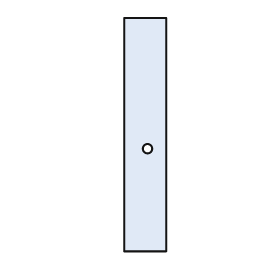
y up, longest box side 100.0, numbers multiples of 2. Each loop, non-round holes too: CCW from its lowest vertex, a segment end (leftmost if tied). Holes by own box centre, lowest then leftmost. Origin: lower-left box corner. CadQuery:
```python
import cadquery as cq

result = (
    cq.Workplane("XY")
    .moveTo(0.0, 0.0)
    .lineTo(18.0, 0.0)
    .lineTo(18.0, 100.0)
    .lineTo(0.0, 100.0)
    .close()
    .moveTo(10.0, 44.0)
    .circle(2.0)
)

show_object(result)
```